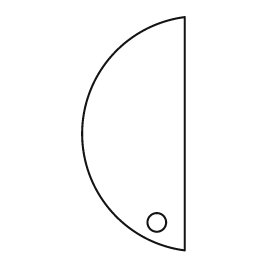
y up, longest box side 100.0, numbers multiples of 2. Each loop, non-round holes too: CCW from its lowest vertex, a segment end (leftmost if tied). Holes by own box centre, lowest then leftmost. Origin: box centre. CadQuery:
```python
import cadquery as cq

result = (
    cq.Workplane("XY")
    .moveTo(22.0, -50.0)
    .lineTo(22.0, 50.0)
    .threePointArc((-22.0, 0.0), (22.0, -50.0))
    .close()
    .moveTo(10.0, -38.0)
    .circle(4.0)
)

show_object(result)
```